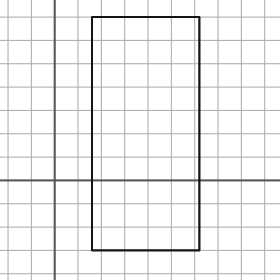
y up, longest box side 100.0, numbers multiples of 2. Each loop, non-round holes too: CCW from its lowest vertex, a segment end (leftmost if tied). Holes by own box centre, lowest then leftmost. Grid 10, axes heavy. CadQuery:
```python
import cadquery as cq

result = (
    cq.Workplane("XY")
    .moveTo(16.0, -30.0)
    .lineTo(62.0, -30.0)
    .lineTo(62.0, 70.0)
    .lineTo(16.0, 70.0)
    .close()
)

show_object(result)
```